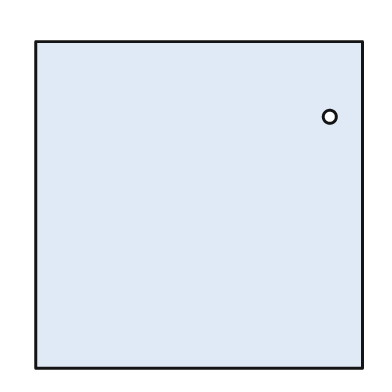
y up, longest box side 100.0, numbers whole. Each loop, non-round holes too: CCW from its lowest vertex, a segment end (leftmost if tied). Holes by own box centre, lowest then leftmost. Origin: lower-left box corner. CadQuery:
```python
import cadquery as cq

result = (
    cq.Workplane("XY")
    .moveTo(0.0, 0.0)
    .lineTo(100.0, 0.0)
    .lineTo(100.0, 100.0)
    .lineTo(0.0, 100.0)
    .close()
    .moveTo(90.0, 77.0)
    .circle(2.0)
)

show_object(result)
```